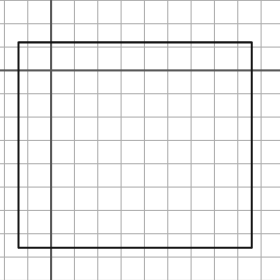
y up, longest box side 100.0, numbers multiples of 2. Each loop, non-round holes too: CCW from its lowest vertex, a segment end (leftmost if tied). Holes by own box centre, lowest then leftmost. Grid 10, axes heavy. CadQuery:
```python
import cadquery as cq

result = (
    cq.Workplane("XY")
    .moveTo(-14.0, -76.0)
    .lineTo(86.0, -76.0)
    .lineTo(86.0, 12.0)
    .lineTo(-14.0, 12.0)
    .close()
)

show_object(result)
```